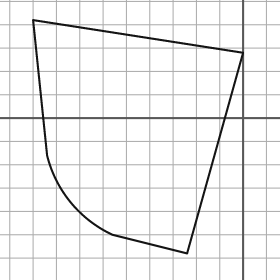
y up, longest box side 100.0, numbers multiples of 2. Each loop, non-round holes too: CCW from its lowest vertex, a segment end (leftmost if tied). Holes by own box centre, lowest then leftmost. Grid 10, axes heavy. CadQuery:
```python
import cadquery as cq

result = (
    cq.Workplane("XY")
    .moveTo(-24.0, -58.0)
    .lineTo(0.0, 28.0)
    .lineTo(-90.0, 42.0)
    .lineTo(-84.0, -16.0)
    .threePointArc((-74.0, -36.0), (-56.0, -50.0))
    .close()
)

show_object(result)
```